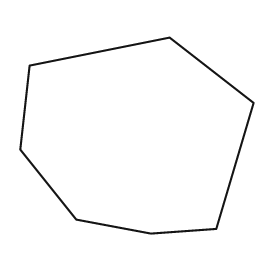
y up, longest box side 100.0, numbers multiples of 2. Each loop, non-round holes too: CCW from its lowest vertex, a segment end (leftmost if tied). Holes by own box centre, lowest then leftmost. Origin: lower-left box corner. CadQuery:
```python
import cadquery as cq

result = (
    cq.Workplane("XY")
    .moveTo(56.0, 0.0)
    .lineTo(84.0, 2.0)
    .lineTo(100.0, 56.0)
    .lineTo(64.0, 84.0)
    .lineTo(4.0, 72.0)
    .lineTo(0.0, 36.0)
    .lineTo(24.0, 6.0)
    .close()
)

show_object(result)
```